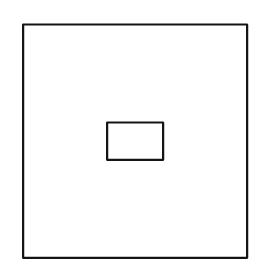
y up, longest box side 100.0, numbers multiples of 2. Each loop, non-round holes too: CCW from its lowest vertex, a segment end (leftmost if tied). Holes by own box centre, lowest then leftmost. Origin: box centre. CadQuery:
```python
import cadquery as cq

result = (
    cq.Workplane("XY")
    .moveTo(-48.0, -50.0)
    .lineTo(48.0, -50.0)
    .lineTo(48.0, 50.0)
    .lineTo(-48.0, 50.0)
    .close()
    .moveTo(-12.0, -8.0)
    .lineTo(12.0, -8.0)
    .lineTo(12.0, 8.0)
    .lineTo(-12.0, 8.0)
    .close()
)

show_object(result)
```